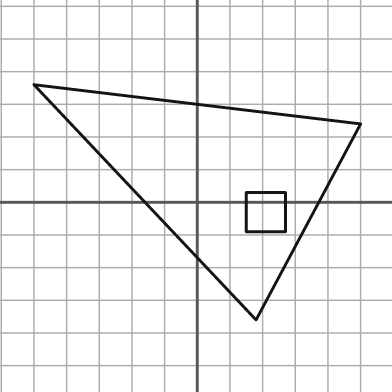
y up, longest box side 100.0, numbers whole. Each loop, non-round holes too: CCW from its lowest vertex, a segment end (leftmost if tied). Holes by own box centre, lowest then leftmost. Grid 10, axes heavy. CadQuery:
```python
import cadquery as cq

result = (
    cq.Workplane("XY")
    .moveTo(18.0, -36.0)
    .lineTo(50.0, 24.0)
    .lineTo(-50.0, 36.0)
    .close()
    .moveTo(15.0, -9.0)
    .lineTo(27.0, -9.0)
    .lineTo(27.0, 3.0)
    .lineTo(15.0, 3.0)
    .close()
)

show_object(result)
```